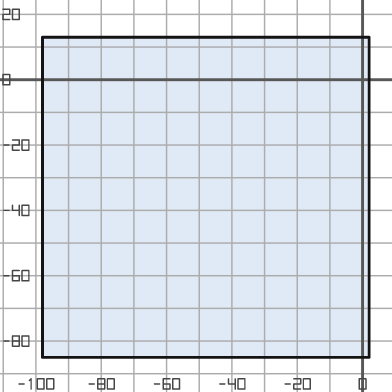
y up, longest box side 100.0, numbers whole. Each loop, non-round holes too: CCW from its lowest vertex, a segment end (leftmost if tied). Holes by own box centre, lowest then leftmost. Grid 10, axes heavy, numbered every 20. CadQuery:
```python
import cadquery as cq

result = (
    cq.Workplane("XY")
    .moveTo(-98.0, -85.0)
    .lineTo(2.0, -85.0)
    .lineTo(2.0, 13.0)
    .lineTo(-98.0, 13.0)
    .close()
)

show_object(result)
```